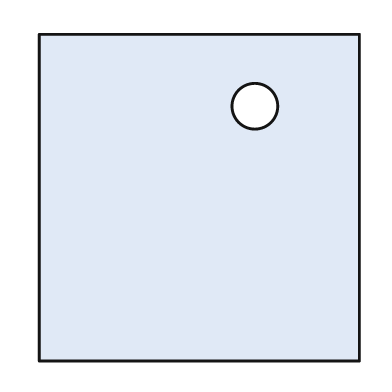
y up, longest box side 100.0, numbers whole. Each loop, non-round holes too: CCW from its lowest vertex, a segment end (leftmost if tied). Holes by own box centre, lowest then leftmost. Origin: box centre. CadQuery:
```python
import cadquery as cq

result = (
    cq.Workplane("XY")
    .moveTo(-49.0, -50.0)
    .lineTo(49.0, -50.0)
    .lineTo(49.0, 50.0)
    .lineTo(-49.0, 50.0)
    .close()
    .moveTo(17.0, 28.0)
    .circle(7.0)
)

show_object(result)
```